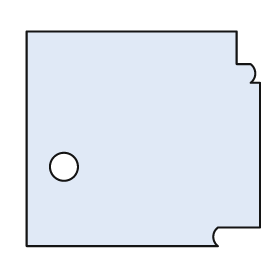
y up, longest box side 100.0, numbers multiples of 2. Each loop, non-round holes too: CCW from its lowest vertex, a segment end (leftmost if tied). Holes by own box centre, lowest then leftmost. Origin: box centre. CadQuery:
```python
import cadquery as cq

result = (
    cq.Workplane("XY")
    .moveTo(-50.0, -46.0)
    .lineTo(32.0, -46.0)
    .threePointArc((30.0, -42.0), (32.0, -38.0))
    .lineTo(50.0, -38.0)
    .lineTo(50.0, 24.0)
    .lineTo(46.0, 24.0)
    .threePointArc((48.0, 28.0), (46.0, 32.0))
    .lineTo(40.0, 32.0)
    .lineTo(40.0, 46.0)
    .lineTo(-50.0, 46.0)
    .close()
    .moveTo(-34.0, -12.0)
    .circle(6.0)
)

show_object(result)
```